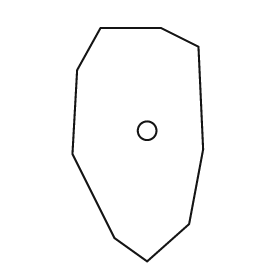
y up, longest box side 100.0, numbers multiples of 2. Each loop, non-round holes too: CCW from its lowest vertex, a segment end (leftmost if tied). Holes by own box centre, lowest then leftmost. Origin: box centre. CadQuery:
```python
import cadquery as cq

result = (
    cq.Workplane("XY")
    .moveTo(4.0, -50.0)
    .lineTo(22.0, -34.0)
    .lineTo(28.0, -2.0)
    .lineTo(26.0, 42.0)
    .lineTo(10.0, 50.0)
    .lineTo(-16.0, 50.0)
    .lineTo(-26.0, 32.0)
    .lineTo(-28.0, -4.0)
    .lineTo(-10.0, -40.0)
    .close()
    .moveTo(4.0, 6.0)
    .circle(4.0)
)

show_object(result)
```